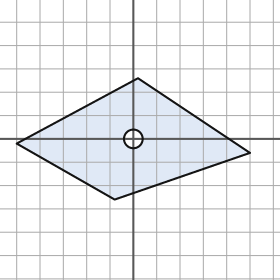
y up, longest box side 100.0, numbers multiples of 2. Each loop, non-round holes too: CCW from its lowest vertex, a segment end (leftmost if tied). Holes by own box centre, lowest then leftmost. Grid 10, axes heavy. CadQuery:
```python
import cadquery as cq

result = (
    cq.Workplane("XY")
    .moveTo(-8.0, -26.0)
    .lineTo(50.0, -6.0)
    .lineTo(2.0, 26.0)
    .lineTo(-50.0, -2.0)
    .close()
    .moveTo(0.0, 0.0)
    .circle(4.0)
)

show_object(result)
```